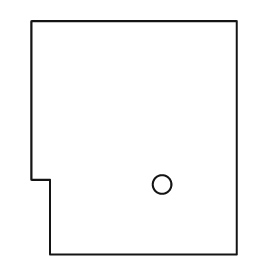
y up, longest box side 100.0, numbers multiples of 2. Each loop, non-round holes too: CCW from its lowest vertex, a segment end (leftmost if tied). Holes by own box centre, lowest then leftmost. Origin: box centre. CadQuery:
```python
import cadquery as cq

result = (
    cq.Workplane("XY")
    .moveTo(-36.0, -50.0)
    .lineTo(44.0, -50.0)
    .lineTo(44.0, 50.0)
    .lineTo(-44.0, 50.0)
    .lineTo(-44.0, -18.0)
    .lineTo(-36.0, -18.0)
    .close()
    .moveTo(12.0, -20.0)
    .circle(4.0)
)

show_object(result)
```